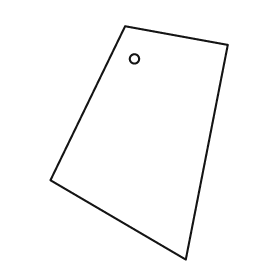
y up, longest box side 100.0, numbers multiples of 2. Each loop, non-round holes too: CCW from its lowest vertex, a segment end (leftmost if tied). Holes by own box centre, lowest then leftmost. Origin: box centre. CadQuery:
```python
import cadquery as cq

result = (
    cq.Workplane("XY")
    .moveTo(20.0, -50.0)
    .lineTo(38.0, 42.0)
    .lineTo(-6.0, 50.0)
    .lineTo(-38.0, -16.0)
    .close()
    .moveTo(-2.0, 36.0)
    .circle(2.0)
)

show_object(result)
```